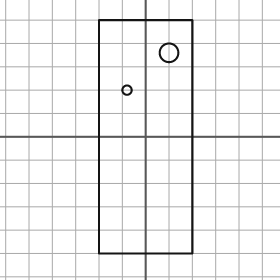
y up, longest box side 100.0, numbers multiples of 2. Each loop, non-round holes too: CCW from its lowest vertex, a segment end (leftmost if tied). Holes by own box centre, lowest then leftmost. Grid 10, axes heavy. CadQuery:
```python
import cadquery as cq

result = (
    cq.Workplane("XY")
    .moveTo(-20.0, -50.0)
    .lineTo(20.0, -50.0)
    .lineTo(20.0, 50.0)
    .lineTo(-20.0, 50.0)
    .close()
    .moveTo(-8.0, 20.0)
    .circle(2.0)
    .moveTo(10.0, 36.0)
    .circle(4.0)
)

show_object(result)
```